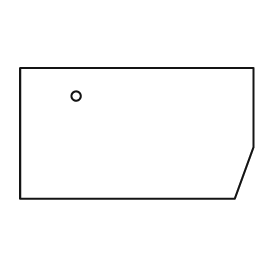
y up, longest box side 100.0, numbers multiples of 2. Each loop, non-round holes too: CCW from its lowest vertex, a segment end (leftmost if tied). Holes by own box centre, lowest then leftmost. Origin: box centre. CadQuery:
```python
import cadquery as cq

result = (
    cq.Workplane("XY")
    .moveTo(-50.0, -28.0)
    .lineTo(42.0, -28.0)
    .lineTo(50.0, -6.0)
    .lineTo(50.0, 28.0)
    .lineTo(-50.0, 28.0)
    .close()
    .moveTo(-26.0, 16.0)
    .circle(2.0)
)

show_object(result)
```